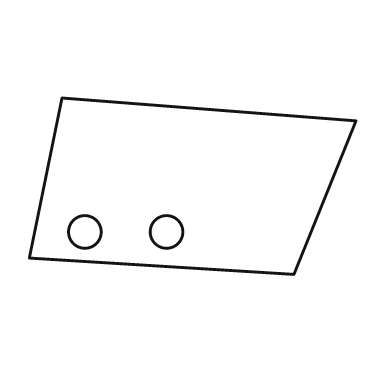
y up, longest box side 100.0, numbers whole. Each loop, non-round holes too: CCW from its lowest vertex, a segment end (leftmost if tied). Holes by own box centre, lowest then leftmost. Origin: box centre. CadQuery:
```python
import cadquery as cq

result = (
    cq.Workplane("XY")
    .moveTo(31.0, -27.0)
    .lineTo(50.0, 20.0)
    .lineTo(-40.0, 27.0)
    .lineTo(-50.0, -22.0)
    .close()
    .moveTo(-33.0, -14.0)
    .circle(5.0)
    .moveTo(-8.0, -14.0)
    .circle(5.0)
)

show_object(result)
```